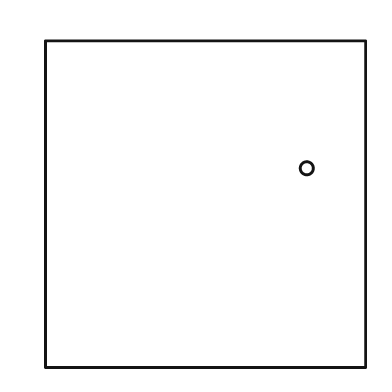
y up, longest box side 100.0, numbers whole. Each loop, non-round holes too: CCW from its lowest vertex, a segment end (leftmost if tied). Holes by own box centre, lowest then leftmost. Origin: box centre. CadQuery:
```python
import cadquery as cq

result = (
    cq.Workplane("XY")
    .moveTo(-49.0, -50.0)
    .lineTo(49.0, -50.0)
    .lineTo(49.0, 50.0)
    .lineTo(-49.0, 50.0)
    .close()
    .moveTo(31.0, 11.0)
    .circle(2.0)
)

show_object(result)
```